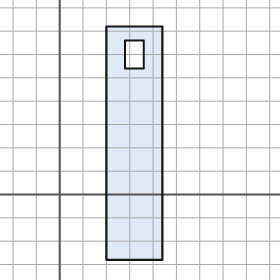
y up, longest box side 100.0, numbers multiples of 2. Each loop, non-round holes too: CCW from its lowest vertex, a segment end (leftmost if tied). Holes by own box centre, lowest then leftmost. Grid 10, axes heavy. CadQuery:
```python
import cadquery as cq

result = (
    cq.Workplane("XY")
    .moveTo(20.0, -28.0)
    .lineTo(44.0, -28.0)
    .lineTo(44.0, 72.0)
    .lineTo(20.0, 72.0)
    .close()
    .moveTo(28.0, 54.0)
    .lineTo(36.0, 54.0)
    .lineTo(36.0, 66.0)
    .lineTo(28.0, 66.0)
    .close()
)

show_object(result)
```